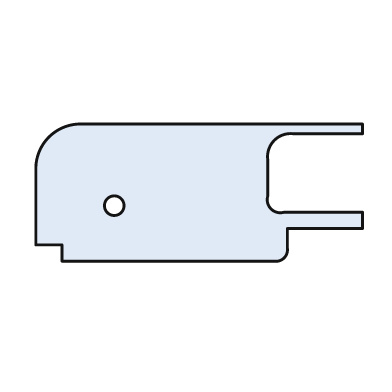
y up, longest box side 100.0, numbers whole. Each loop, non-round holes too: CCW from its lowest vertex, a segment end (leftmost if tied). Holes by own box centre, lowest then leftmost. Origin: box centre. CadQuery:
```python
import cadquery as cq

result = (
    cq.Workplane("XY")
    .moveTo(-42.0, -21.0)
    .lineTo(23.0, -21.0)
    .threePointArc((26.0, -20.0), (27.0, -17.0))
    .lineTo(27.0, -11.0)
    .lineTo(50.0, -11.0)
    .lineTo(50.0, -6.0)
    .lineTo(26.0, -6.0)
    .threePointArc((22.0, -5.0), (21.0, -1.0))
    .lineTo(21.0, 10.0)
    .threePointArc((23.0, 16.0), (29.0, 18.0))
    .lineTo(50.0, 18.0)
    .lineTo(50.0, 21.0)
    .lineTo(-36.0, 21.0)
    .threePointArc((-46.0, 17.0), (-50.0, 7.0))
    .lineTo(-50.0, -16.0)
    .lineTo(-42.0, -16.0)
    .close()
    .moveTo(-26.0, -4.0)
    .circle(3.0)
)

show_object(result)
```